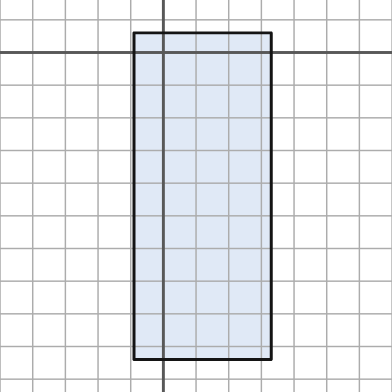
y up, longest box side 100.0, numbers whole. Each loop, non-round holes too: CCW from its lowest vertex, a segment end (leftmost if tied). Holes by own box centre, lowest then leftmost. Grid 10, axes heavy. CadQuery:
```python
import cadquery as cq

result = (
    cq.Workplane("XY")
    .moveTo(-9.0, -94.0)
    .lineTo(33.0, -94.0)
    .lineTo(33.0, 6.0)
    .lineTo(-9.0, 6.0)
    .close()
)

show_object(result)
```